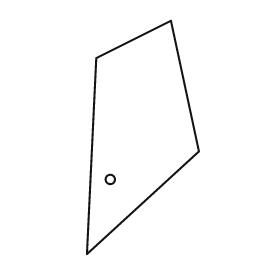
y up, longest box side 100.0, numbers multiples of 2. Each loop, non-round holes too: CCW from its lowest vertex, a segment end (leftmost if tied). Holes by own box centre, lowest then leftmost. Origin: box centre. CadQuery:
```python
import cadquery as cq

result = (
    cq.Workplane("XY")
    .moveTo(-24.0, -50.0)
    .lineTo(24.0, -6.0)
    .lineTo(12.0, 50.0)
    .lineTo(-20.0, 34.0)
    .close()
    .moveTo(-14.0, -18.0)
    .circle(2.0)
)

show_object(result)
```